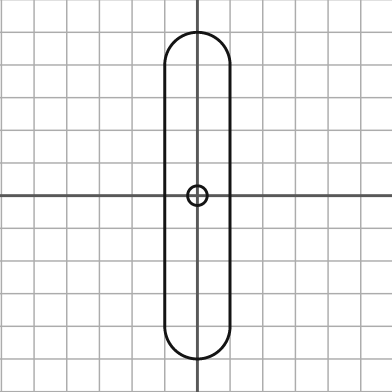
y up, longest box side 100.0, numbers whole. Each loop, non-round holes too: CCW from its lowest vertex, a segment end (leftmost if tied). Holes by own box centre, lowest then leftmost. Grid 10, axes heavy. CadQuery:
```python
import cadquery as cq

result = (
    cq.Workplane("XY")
    .moveTo(-10.0, -40.0)
    .threePointArc((0.0, -50.0), (10.0, -40.0))
    .lineTo(10.0, 40.0)
    .threePointArc((0.0, 50.0), (-10.0, 40.0))
    .close()
    .moveTo(0.0, 0.0)
    .circle(3.0)
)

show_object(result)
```